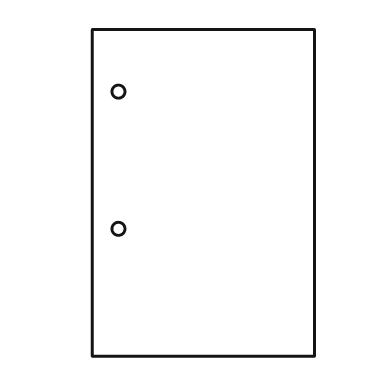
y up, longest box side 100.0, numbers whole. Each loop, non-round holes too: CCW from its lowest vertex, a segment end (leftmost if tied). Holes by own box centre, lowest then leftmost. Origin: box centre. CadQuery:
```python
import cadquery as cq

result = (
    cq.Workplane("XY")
    .moveTo(-34.0, -50.0)
    .lineTo(34.0, -50.0)
    .lineTo(34.0, 50.0)
    .lineTo(-34.0, 50.0)
    .close()
    .moveTo(-26.0, -11.0)
    .circle(2.0)
    .moveTo(-26.0, 31.0)
    .circle(2.0)
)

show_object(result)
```